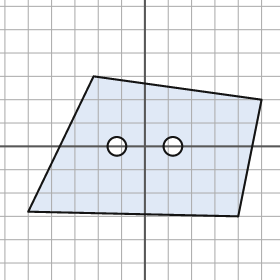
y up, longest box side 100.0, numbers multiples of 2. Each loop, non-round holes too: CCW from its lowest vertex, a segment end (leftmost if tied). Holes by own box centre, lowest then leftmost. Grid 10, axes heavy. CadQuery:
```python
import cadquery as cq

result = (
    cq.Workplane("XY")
    .moveTo(40.0, -30.0)
    .lineTo(50.0, 20.0)
    .lineTo(-22.0, 30.0)
    .lineTo(-50.0, -28.0)
    .close()
    .moveTo(-12.0, 0.0)
    .circle(4.0)
    .moveTo(12.0, 0.0)
    .circle(4.0)
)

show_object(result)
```